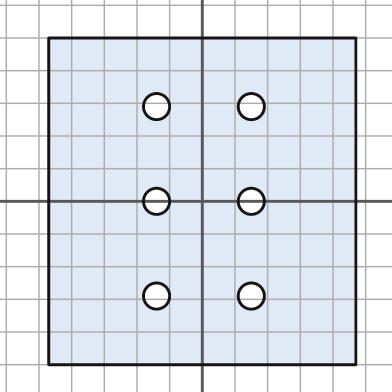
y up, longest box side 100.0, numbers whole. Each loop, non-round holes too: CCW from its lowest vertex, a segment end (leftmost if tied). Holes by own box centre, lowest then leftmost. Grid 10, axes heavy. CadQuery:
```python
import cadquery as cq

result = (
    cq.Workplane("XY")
    .moveTo(-47.0, -50.0)
    .lineTo(47.0, -50.0)
    .lineTo(47.0, 50.0)
    .lineTo(-47.0, 50.0)
    .close()
    .moveTo(-14.0, -29.0)
    .circle(4.0)
    .moveTo(15.0, -29.0)
    .circle(4.0)
    .moveTo(-14.0, 0.0)
    .circle(4.0)
    .moveTo(15.0, 0.0)
    .circle(4.0)
    .moveTo(-14.0, 29.0)
    .circle(4.0)
    .moveTo(15.0, 29.0)
    .circle(4.0)
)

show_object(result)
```